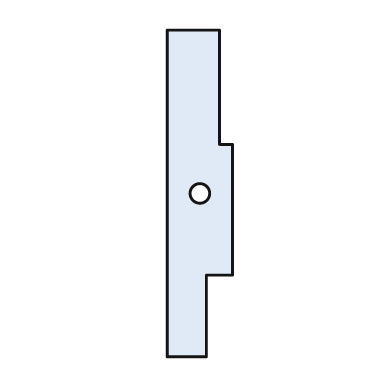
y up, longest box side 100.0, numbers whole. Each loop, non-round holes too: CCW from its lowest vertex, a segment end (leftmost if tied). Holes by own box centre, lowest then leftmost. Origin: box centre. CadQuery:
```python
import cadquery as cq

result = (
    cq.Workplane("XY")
    .moveTo(-10.0, -50.0)
    .lineTo(2.0, -50.0)
    .lineTo(2.0, -25.0)
    .lineTo(10.0, -25.0)
    .lineTo(10.0, 15.0)
    .lineTo(6.0, 15.0)
    .lineTo(6.0, 50.0)
    .lineTo(-10.0, 50.0)
    .close()
    .moveTo(0.0, 0.0)
    .circle(3.0)
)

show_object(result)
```